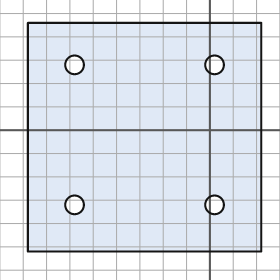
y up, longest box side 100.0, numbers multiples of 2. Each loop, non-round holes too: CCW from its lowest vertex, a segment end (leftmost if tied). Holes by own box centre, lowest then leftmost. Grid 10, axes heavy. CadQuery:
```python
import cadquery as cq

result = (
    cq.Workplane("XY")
    .moveTo(-78.0, -52.0)
    .lineTo(22.0, -52.0)
    .lineTo(22.0, 46.0)
    .lineTo(-78.0, 46.0)
    .close()
    .moveTo(-58.0, -32.0)
    .circle(4.0)
    .moveTo(2.0, -32.0)
    .circle(4.0)
    .moveTo(-58.0, 28.0)
    .circle(4.0)
    .moveTo(2.0, 28.0)
    .circle(4.0)
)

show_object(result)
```